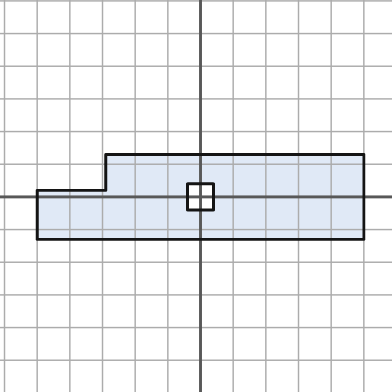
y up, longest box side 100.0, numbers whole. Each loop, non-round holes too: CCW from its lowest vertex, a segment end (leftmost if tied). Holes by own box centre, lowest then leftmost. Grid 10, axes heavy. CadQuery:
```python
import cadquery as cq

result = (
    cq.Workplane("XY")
    .moveTo(-50.0, -13.0)
    .lineTo(50.0, -13.0)
    .lineTo(50.0, 13.0)
    .lineTo(-29.0, 13.0)
    .lineTo(-29.0, 2.0)
    .lineTo(-50.0, 2.0)
    .close()
    .moveTo(-4.0, -4.0)
    .lineTo(4.0, -4.0)
    .lineTo(4.0, 4.0)
    .lineTo(-4.0, 4.0)
    .close()
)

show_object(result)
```